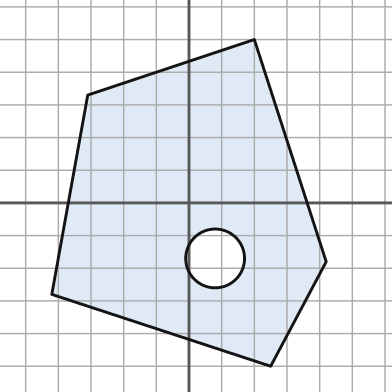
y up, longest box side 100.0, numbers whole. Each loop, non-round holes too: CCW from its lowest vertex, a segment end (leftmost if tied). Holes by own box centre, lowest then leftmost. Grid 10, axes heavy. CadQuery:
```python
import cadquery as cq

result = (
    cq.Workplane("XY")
    .moveTo(25.0, -50.0)
    .lineTo(42.0, -18.0)
    .lineTo(20.0, 50.0)
    .lineTo(-31.0, 33.0)
    .lineTo(-42.0, -28.0)
    .close()
    .moveTo(8.0, -17.0)
    .circle(9.0)
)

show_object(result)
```